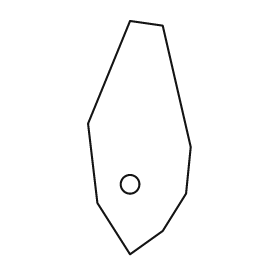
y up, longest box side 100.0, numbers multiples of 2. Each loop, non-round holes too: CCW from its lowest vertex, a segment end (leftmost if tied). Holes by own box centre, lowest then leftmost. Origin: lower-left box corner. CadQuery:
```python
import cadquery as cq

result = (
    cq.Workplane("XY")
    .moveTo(18.0, 0.0)
    .lineTo(32.0, 10.0)
    .lineTo(42.0, 26.0)
    .lineTo(44.0, 46.0)
    .lineTo(32.0, 98.0)
    .lineTo(18.0, 100.0)
    .lineTo(0.0, 56.0)
    .lineTo(4.0, 22.0)
    .close()
    .moveTo(18.0, 30.0)
    .circle(4.0)
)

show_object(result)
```